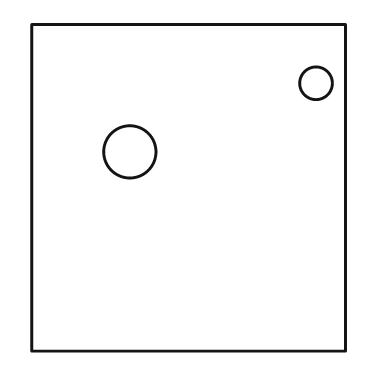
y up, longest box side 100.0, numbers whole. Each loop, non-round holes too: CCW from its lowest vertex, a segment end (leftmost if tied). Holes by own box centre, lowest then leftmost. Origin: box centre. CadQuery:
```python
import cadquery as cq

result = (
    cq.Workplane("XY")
    .moveTo(-48.0, -50.0)
    .lineTo(48.0, -50.0)
    .lineTo(48.0, 50.0)
    .lineTo(-48.0, 50.0)
    .close()
    .moveTo(-18.0, 11.0)
    .circle(8.0)
    .moveTo(39.0, 32.0)
    .circle(5.0)
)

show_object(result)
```